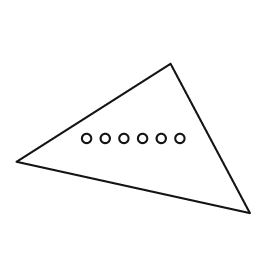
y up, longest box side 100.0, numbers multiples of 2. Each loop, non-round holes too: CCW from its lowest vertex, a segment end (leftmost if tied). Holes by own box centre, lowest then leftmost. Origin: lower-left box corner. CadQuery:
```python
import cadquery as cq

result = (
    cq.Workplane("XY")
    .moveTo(100.0, 0.0)
    .lineTo(66.0, 64.0)
    .lineTo(0.0, 22.0)
    .close()
    .moveTo(30.0, 32.0)
    .circle(2.0)
    .moveTo(38.0, 32.0)
    .circle(2.0)
    .moveTo(46.0, 32.0)
    .circle(2.0)
    .moveTo(54.0, 32.0)
    .circle(2.0)
    .moveTo(62.0, 32.0)
    .circle(2.0)
    .moveTo(70.0, 32.0)
    .circle(2.0)
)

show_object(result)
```